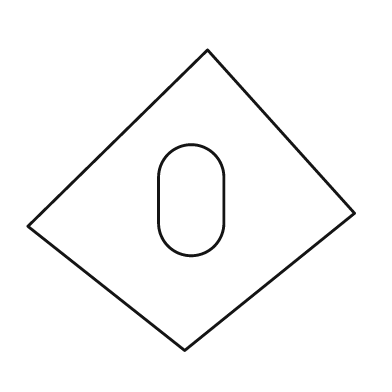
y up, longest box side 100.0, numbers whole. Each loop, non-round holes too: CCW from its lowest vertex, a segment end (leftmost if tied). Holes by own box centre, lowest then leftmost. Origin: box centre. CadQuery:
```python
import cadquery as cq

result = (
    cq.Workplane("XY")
    .moveTo(-2.0, -46.0)
    .lineTo(50.0, -4.0)
    .lineTo(5.0, 46.0)
    .lineTo(-50.0, -8.0)
    .close()
    .moveTo(-10.0, -7.0)
    .threePointArc((0.0, -17.0), (10.0, -7.0))
    .lineTo(10.0, 7.0)
    .threePointArc((0.0, 17.0), (-10.0, 7.0))
    .close()
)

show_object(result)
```